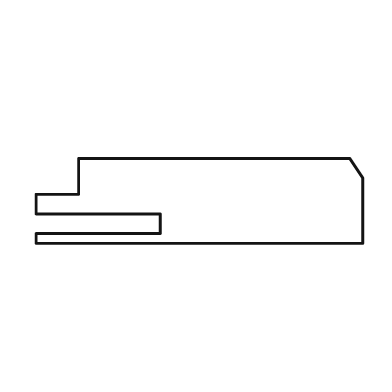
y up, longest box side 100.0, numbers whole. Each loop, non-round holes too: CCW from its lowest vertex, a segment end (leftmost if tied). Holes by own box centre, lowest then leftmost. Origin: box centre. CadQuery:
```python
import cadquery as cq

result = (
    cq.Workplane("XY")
    .moveTo(-50.0, -13.0)
    .lineTo(50.0, -13.0)
    .lineTo(50.0, 7.0)
    .lineTo(46.0, 13.0)
    .lineTo(-37.0, 13.0)
    .lineTo(-37.0, 2.0)
    .lineTo(-50.0, 2.0)
    .lineTo(-50.0, -4.0)
    .lineTo(-12.0, -4.0)
    .lineTo(-12.0, -10.0)
    .lineTo(-50.0, -10.0)
    .close()
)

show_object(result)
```